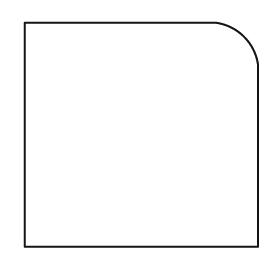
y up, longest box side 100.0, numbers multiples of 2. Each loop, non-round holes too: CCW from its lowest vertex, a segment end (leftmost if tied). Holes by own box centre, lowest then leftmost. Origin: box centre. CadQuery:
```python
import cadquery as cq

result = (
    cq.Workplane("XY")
    .moveTo(-50.0, -48.0)
    .lineTo(50.0, -48.0)
    .lineTo(50.0, 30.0)
    .threePointArc((44.0, 42.0), (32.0, 48.0))
    .lineTo(-50.0, 48.0)
    .close()
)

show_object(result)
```